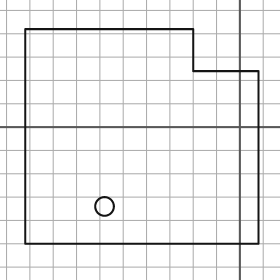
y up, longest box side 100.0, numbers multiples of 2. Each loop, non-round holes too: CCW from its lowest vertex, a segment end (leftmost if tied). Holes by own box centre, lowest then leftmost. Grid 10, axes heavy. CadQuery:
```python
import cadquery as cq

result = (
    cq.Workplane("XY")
    .moveTo(-92.0, -50.0)
    .lineTo(8.0, -50.0)
    .lineTo(8.0, 24.0)
    .lineTo(-20.0, 24.0)
    .lineTo(-20.0, 42.0)
    .lineTo(-92.0, 42.0)
    .close()
    .moveTo(-58.0, -34.0)
    .circle(4.0)
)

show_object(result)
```